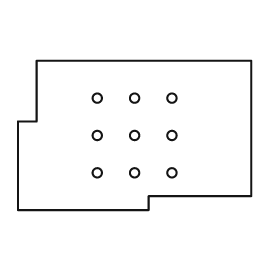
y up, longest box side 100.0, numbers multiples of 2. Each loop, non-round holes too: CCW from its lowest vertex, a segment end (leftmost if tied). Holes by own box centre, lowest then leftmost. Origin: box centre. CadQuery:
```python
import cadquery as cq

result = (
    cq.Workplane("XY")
    .moveTo(-50.0, -32.0)
    .lineTo(6.0, -32.0)
    .lineTo(6.0, -26.0)
    .lineTo(50.0, -26.0)
    .lineTo(50.0, 32.0)
    .lineTo(-42.0, 32.0)
    .lineTo(-42.0, 6.0)
    .lineTo(-50.0, 6.0)
    .close()
    .moveTo(-16.0, -16.0)
    .circle(2.0)
    .moveTo(0.0, -16.0)
    .circle(2.0)
    .moveTo(16.0, -16.0)
    .circle(2.0)
    .moveTo(-16.0, 0.0)
    .circle(2.0)
    .moveTo(0.0, 0.0)
    .circle(2.0)
    .moveTo(16.0, 0.0)
    .circle(2.0)
    .moveTo(-16.0, 16.0)
    .circle(2.0)
    .moveTo(0.0, 16.0)
    .circle(2.0)
    .moveTo(16.0, 16.0)
    .circle(2.0)
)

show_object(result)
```